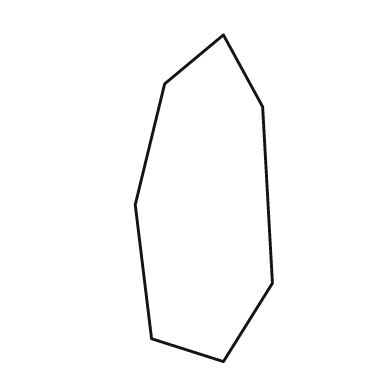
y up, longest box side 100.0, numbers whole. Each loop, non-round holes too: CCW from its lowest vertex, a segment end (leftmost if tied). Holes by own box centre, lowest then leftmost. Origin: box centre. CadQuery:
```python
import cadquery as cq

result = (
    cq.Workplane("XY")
    .moveTo(6.0, -50.0)
    .lineTo(21.0, -26.0)
    .lineTo(18.0, 28.0)
    .lineTo(6.0, 50.0)
    .lineTo(-12.0, 35.0)
    .lineTo(-21.0, -2.0)
    .lineTo(-16.0, -43.0)
    .close()
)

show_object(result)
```